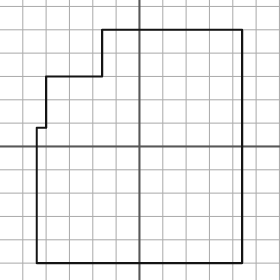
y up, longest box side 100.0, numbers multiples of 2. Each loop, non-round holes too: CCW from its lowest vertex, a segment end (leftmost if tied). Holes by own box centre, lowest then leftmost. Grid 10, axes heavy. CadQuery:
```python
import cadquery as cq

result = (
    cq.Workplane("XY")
    .moveTo(-44.0, -50.0)
    .lineTo(44.0, -50.0)
    .lineTo(44.0, 50.0)
    .lineTo(-16.0, 50.0)
    .lineTo(-16.0, 30.0)
    .lineTo(-40.0, 30.0)
    .lineTo(-40.0, 8.0)
    .lineTo(-44.0, 8.0)
    .close()
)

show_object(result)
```